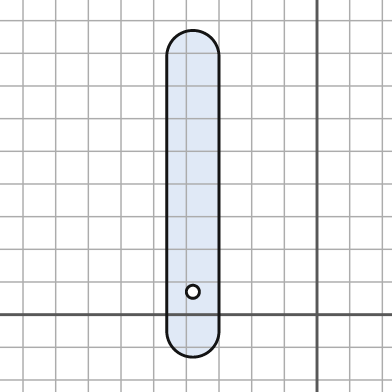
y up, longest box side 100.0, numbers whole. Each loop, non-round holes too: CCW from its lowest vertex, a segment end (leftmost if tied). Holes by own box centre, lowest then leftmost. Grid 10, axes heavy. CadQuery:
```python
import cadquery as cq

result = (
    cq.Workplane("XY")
    .moveTo(-46.0, -5.0)
    .threePointArc((-38.0, -13.0), (-30.0, -5.0))
    .lineTo(-30.0, 79.0)
    .threePointArc((-38.0, 87.0), (-46.0, 79.0))
    .close()
    .moveTo(-38.0, 7.0)
    .circle(2.0)
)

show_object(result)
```